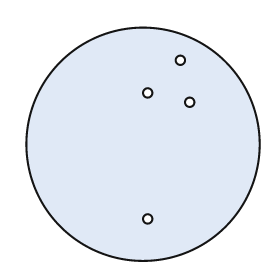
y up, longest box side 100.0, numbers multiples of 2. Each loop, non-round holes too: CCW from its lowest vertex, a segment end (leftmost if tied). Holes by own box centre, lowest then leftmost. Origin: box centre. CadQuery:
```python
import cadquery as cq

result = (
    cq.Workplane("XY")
    .moveTo(0.0, 0.0)
    .circle(50.0)
    .moveTo(2.0, -32.0)
    .circle(2.0)
    .moveTo(20.0, 18.0)
    .circle(2.0)
    .moveTo(2.0, 22.0)
    .circle(2.0)
    .moveTo(16.0, 36.0)
    .circle(2.0)
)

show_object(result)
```